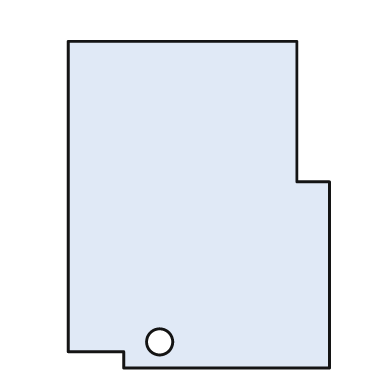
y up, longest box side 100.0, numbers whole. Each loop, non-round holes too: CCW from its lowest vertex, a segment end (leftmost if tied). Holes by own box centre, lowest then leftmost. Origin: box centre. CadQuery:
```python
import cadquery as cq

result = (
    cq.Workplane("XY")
    .moveTo(-23.0, -50.0)
    .lineTo(40.0, -50.0)
    .lineTo(40.0, 7.0)
    .lineTo(30.0, 7.0)
    .lineTo(30.0, 50.0)
    .lineTo(-40.0, 50.0)
    .lineTo(-40.0, -45.0)
    .lineTo(-23.0, -45.0)
    .close()
    .moveTo(-12.0, -42.0)
    .circle(4.0)
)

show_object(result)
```